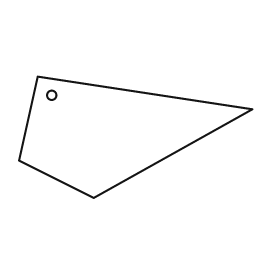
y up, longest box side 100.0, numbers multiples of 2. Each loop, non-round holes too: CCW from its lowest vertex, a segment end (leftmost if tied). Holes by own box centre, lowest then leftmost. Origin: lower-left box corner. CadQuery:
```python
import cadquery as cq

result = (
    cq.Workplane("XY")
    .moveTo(32.0, 0.0)
    .lineTo(100.0, 38.0)
    .lineTo(8.0, 52.0)
    .lineTo(0.0, 16.0)
    .close()
    .moveTo(14.0, 44.0)
    .circle(2.0)
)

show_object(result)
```